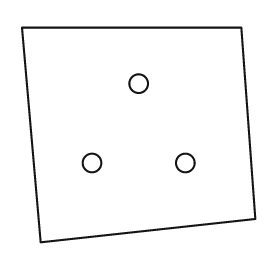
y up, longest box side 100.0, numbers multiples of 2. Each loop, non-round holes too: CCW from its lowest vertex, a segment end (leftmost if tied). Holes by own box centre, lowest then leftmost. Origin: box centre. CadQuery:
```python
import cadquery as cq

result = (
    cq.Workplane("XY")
    .moveTo(-42.0, -46.0)
    .lineTo(50.0, -36.0)
    .lineTo(44.0, 46.0)
    .lineTo(-50.0, 46.0)
    .close()
    .moveTo(-20.0, -12.0)
    .circle(4.0)
    .moveTo(20.0, -12.0)
    .circle(4.0)
    .moveTo(0.0, 22.0)
    .circle(4.0)
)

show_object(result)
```